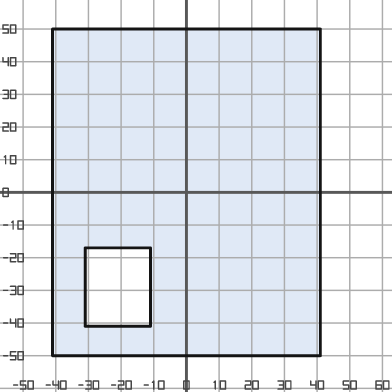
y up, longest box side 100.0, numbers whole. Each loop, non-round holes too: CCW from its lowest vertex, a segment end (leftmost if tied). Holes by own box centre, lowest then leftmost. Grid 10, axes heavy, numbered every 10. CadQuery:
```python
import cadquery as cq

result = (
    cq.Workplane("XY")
    .moveTo(-41.0, -50.0)
    .lineTo(41.0, -50.0)
    .lineTo(41.0, 50.0)
    .lineTo(-41.0, 50.0)
    .close()
    .moveTo(-31.0, -41.0)
    .lineTo(-11.0, -41.0)
    .lineTo(-11.0, -17.0)
    .lineTo(-31.0, -17.0)
    .close()
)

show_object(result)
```